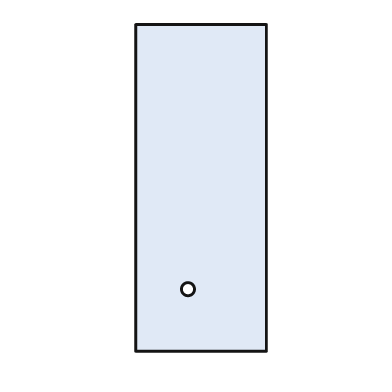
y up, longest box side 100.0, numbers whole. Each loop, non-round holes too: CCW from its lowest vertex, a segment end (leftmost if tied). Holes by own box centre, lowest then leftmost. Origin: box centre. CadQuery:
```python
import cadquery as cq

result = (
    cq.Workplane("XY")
    .moveTo(-20.0, -50.0)
    .lineTo(20.0, -50.0)
    .lineTo(20.0, 50.0)
    .lineTo(-20.0, 50.0)
    .close()
    .moveTo(-4.0, -31.0)
    .circle(2.0)
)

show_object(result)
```